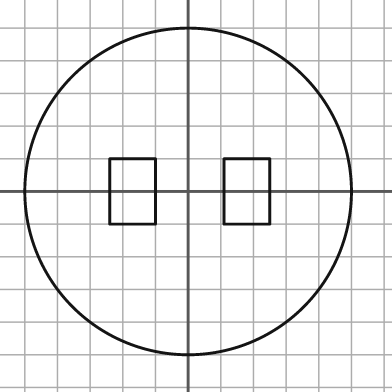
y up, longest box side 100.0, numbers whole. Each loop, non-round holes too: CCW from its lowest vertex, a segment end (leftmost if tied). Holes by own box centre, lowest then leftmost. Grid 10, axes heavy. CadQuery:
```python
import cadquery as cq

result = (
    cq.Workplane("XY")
    .moveTo(0.0, 0.0)
    .circle(50.0)
    .moveTo(-24.0, -10.0)
    .lineTo(-10.0, -10.0)
    .lineTo(-10.0, 10.0)
    .lineTo(-24.0, 10.0)
    .close()
    .moveTo(11.0, -10.0)
    .lineTo(25.0, -10.0)
    .lineTo(25.0, 10.0)
    .lineTo(11.0, 10.0)
    .close()
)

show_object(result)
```